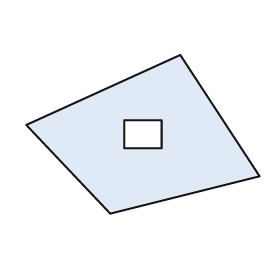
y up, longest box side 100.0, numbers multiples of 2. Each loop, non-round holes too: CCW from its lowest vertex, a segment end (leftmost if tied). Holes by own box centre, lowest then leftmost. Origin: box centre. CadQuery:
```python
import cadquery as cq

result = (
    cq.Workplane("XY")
    .moveTo(-14.0, -34.0)
    .lineTo(50.0, -18.0)
    .lineTo(16.0, 34.0)
    .lineTo(-50.0, 4.0)
    .close()
    .moveTo(-8.0, -6.0)
    .lineTo(8.0, -6.0)
    .lineTo(8.0, 6.0)
    .lineTo(-8.0, 6.0)
    .close()
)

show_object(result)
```